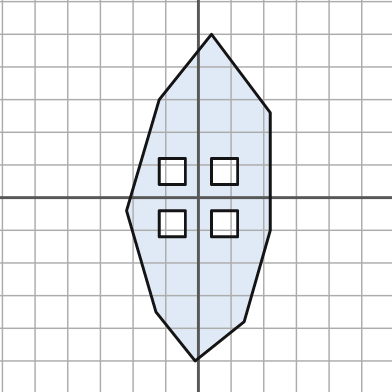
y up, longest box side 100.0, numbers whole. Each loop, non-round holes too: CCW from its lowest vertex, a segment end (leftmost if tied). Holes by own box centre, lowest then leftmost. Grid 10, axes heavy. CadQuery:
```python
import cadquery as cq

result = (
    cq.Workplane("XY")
    .moveTo(-1.0, -50.0)
    .lineTo(14.0, -38.0)
    .lineTo(22.0, -10.0)
    .lineTo(22.0, 26.0)
    .lineTo(4.0, 50.0)
    .lineTo(-12.0, 30.0)
    .lineTo(-22.0, -4.0)
    .lineTo(-13.0, -35.0)
    .close()
    .moveTo(-12.0, -12.0)
    .lineTo(-4.0, -12.0)
    .lineTo(-4.0, -4.0)
    .lineTo(-12.0, -4.0)
    .close()
    .moveTo(4.0, -12.0)
    .lineTo(12.0, -12.0)
    .lineTo(12.0, -4.0)
    .lineTo(4.0, -4.0)
    .close()
    .moveTo(-12.0, 4.0)
    .lineTo(-4.0, 4.0)
    .lineTo(-4.0, 12.0)
    .lineTo(-12.0, 12.0)
    .close()
    .moveTo(4.0, 4.0)
    .lineTo(12.0, 4.0)
    .lineTo(12.0, 12.0)
    .lineTo(4.0, 12.0)
    .close()
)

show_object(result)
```